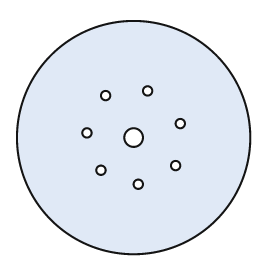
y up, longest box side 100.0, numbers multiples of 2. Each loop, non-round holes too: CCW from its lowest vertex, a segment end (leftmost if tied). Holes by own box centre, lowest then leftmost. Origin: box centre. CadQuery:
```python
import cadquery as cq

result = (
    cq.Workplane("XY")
    .moveTo(0.0, 0.0)
    .circle(50.0)
    .moveTo(2.0, -20.0)
    .circle(2.0)
    .moveTo(-14.0, -14.0)
    .circle(2.0)
    .moveTo(18.0, -12.0)
    .circle(2.0)
    .moveTo(0.0, 0.0)
    .circle(4.0)
    .moveTo(-20.0, 2.0)
    .circle(2.0)
    .moveTo(20.0, 6.0)
    .circle(2.0)
    .moveTo(-12.0, 18.0)
    .circle(2.0)
    .moveTo(6.0, 20.0)
    .circle(2.0)
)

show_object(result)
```